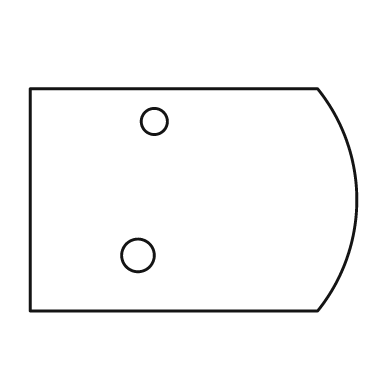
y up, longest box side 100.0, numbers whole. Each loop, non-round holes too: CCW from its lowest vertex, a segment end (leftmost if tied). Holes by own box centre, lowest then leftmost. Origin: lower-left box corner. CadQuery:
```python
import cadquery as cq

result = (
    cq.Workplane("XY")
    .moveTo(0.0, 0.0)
    .lineTo(88.0, 0.0)
    .threePointArc((100.0, 34.0), (88.0, 68.0))
    .lineTo(0.0, 68.0)
    .close()
    .moveTo(33.0, 17.0)
    .circle(5.0)
    .moveTo(38.0, 58.0)
    .circle(4.0)
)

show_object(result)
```